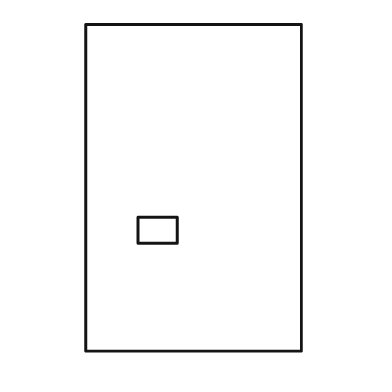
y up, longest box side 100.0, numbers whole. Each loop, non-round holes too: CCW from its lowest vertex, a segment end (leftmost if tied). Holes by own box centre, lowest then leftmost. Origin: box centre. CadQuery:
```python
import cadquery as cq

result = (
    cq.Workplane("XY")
    .moveTo(-33.0, -50.0)
    .lineTo(33.0, -50.0)
    .lineTo(33.0, 50.0)
    .lineTo(-33.0, 50.0)
    .close()
    .moveTo(-17.0, -17.0)
    .lineTo(-5.0, -17.0)
    .lineTo(-5.0, -9.0)
    .lineTo(-17.0, -9.0)
    .close()
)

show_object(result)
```